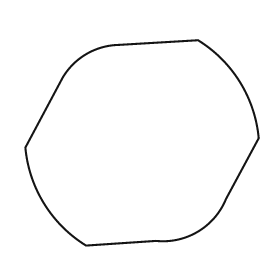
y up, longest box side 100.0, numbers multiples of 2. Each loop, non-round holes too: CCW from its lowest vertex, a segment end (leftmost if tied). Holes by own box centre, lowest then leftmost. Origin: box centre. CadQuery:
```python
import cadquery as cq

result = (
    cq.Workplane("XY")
    .moveTo(-24.0, -44.0)
    .lineTo(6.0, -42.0)
    .threePointArc((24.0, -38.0), (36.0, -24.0))
    .lineTo(50.0, 2.0)
    .threePointArc((42.0, 26.0), (24.0, 44.0))
    .lineTo(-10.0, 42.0)
    .threePointArc((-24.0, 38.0), (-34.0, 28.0))
    .lineTo(-50.0, -2.0)
    .threePointArc((-42.0, -26.0), (-24.0, -44.0))
    .close()
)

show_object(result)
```